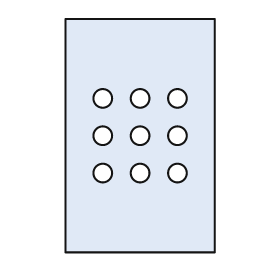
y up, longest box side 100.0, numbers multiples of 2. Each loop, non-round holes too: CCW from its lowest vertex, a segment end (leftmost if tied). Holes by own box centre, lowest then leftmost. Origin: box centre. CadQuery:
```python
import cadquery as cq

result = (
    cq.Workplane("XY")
    .moveTo(-32.0, -50.0)
    .lineTo(32.0, -50.0)
    .lineTo(32.0, 50.0)
    .lineTo(-32.0, 50.0)
    .close()
    .moveTo(-16.0, -16.0)
    .circle(4.0)
    .moveTo(0.0, -16.0)
    .circle(4.0)
    .moveTo(16.0, -16.0)
    .circle(4.0)
    .moveTo(-16.0, 0.0)
    .circle(4.0)
    .moveTo(0.0, 0.0)
    .circle(4.0)
    .moveTo(16.0, 0.0)
    .circle(4.0)
    .moveTo(-16.0, 16.0)
    .circle(4.0)
    .moveTo(0.0, 16.0)
    .circle(4.0)
    .moveTo(16.0, 16.0)
    .circle(4.0)
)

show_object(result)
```